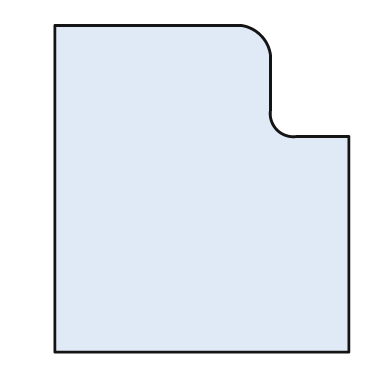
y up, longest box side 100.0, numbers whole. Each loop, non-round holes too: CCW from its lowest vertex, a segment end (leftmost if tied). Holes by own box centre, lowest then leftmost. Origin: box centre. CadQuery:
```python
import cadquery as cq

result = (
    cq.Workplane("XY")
    .moveTo(-45.0, -50.0)
    .lineTo(45.0, -50.0)
    .lineTo(45.0, 16.0)
    .lineTo(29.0, 16.0)
    .threePointArc((23.0, 18.0), (21.0, 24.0))
    .lineTo(21.0, 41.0)
    .threePointArc((18.0, 47.0), (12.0, 50.0))
    .lineTo(-45.0, 50.0)
    .close()
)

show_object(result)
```